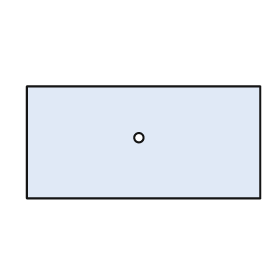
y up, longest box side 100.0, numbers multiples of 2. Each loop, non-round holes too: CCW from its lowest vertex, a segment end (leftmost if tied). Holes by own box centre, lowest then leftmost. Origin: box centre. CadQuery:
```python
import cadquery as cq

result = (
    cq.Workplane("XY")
    .moveTo(-50.0, -24.0)
    .lineTo(50.0, -24.0)
    .lineTo(50.0, 24.0)
    .lineTo(-50.0, 24.0)
    .close()
    .moveTo(-2.0, 2.0)
    .circle(2.0)
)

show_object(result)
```